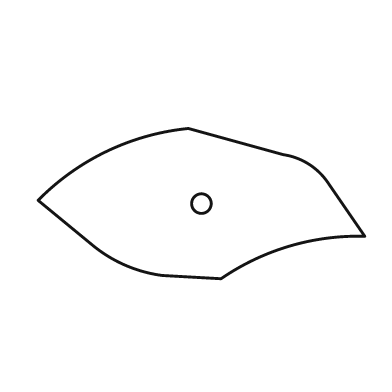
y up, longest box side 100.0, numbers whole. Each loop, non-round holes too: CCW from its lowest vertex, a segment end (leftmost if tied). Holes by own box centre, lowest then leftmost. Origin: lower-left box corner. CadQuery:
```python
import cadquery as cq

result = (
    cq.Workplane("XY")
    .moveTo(56.0, 0.0)
    .threePointArc((77.0, 10.0), (100.0, 13.0))
    .lineTo(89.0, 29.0)
    .threePointArc((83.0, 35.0), (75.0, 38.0))
    .lineTo(46.0, 46.0)
    .threePointArc((21.0, 39.0), (0.0, 24.0))
    .lineTo(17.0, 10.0)
    .threePointArc((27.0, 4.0), (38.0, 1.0))
    .close()
    .moveTo(50.0, 23.0)
    .circle(3.0)
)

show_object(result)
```